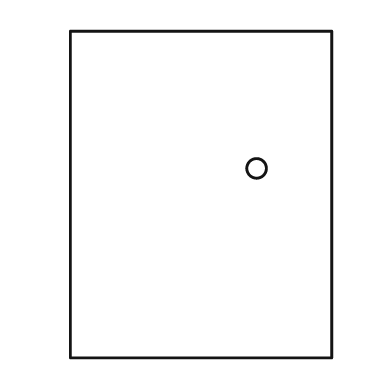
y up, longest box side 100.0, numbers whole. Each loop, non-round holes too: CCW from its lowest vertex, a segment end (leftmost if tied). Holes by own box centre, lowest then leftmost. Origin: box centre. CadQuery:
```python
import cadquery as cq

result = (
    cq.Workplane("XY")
    .moveTo(-40.0, -50.0)
    .lineTo(40.0, -50.0)
    .lineTo(40.0, 50.0)
    .lineTo(-40.0, 50.0)
    .close()
    .moveTo(17.0, 8.0)
    .circle(3.0)
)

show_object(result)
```